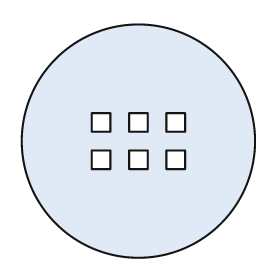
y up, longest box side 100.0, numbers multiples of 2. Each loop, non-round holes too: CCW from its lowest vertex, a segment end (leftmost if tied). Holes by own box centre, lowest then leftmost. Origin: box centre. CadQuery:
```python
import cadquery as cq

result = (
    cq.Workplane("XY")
    .moveTo(0.0, 0.0)
    .circle(50.0)
    .moveTo(-20.0, -12.0)
    .lineTo(-12.0, -12.0)
    .lineTo(-12.0, -4.0)
    .lineTo(-20.0, -4.0)
    .close()
    .moveTo(-4.0, -12.0)
    .lineTo(4.0, -12.0)
    .lineTo(4.0, -4.0)
    .lineTo(-4.0, -4.0)
    .close()
    .moveTo(12.0, -12.0)
    .lineTo(20.0, -12.0)
    .lineTo(20.0, -4.0)
    .lineTo(12.0, -4.0)
    .close()
    .moveTo(-20.0, 4.0)
    .lineTo(-12.0, 4.0)
    .lineTo(-12.0, 12.0)
    .lineTo(-20.0, 12.0)
    .close()
    .moveTo(-4.0, 4.0)
    .lineTo(4.0, 4.0)
    .lineTo(4.0, 12.0)
    .lineTo(-4.0, 12.0)
    .close()
    .moveTo(12.0, 4.0)
    .lineTo(20.0, 4.0)
    .lineTo(20.0, 12.0)
    .lineTo(12.0, 12.0)
    .close()
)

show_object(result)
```